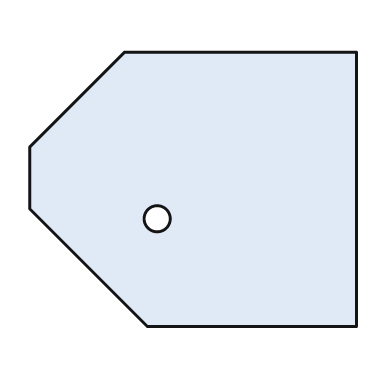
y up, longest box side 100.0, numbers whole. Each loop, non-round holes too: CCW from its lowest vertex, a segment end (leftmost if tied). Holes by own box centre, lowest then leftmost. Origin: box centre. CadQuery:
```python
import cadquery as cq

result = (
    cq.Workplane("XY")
    .moveTo(-14.0, -42.0)
    .lineTo(50.0, -42.0)
    .lineTo(50.0, 42.0)
    .lineTo(-21.0, 42.0)
    .lineTo(-50.0, 13.0)
    .lineTo(-50.0, -6.0)
    .close()
    .moveTo(-11.0, -9.0)
    .circle(4.0)
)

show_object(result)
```